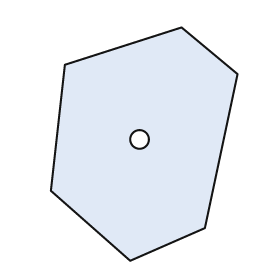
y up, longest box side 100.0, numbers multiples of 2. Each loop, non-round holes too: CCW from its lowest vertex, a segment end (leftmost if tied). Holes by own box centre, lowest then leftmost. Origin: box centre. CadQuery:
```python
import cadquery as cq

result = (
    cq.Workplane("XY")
    .moveTo(-6.0, -50.0)
    .lineTo(26.0, -36.0)
    .lineTo(40.0, 30.0)
    .lineTo(16.0, 50.0)
    .lineTo(-34.0, 34.0)
    .lineTo(-40.0, -20.0)
    .close()
    .moveTo(-2.0, 2.0)
    .circle(4.0)
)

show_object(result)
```